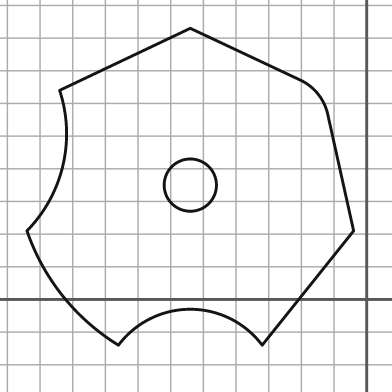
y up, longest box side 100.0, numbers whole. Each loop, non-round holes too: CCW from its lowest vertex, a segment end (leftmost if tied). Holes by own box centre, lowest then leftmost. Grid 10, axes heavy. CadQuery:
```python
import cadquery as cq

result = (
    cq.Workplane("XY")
    .moveTo(-76.0, -14.0)
    .threePointArc((-54.0, -3.0), (-32.0, -14.0))
    .lineTo(-4.0, 21.0)
    .lineTo(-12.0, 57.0)
    .threePointArc((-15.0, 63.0), (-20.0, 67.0))
    .lineTo(-54.0, 83.0)
    .lineTo(-94.0, 64.0)
    .threePointArc((-93.0, 41.0), (-104.0, 21.0))
    .threePointArc((-93.0, 1.0), (-76.0, -14.0))
    .close()
    .moveTo(-54.0, 35.0)
    .circle(8.0)
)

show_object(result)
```